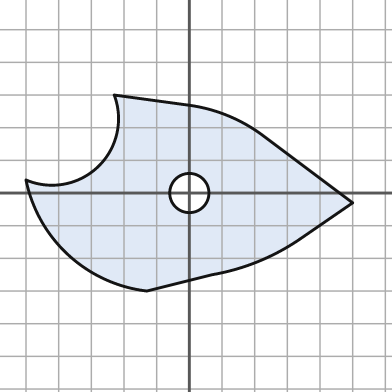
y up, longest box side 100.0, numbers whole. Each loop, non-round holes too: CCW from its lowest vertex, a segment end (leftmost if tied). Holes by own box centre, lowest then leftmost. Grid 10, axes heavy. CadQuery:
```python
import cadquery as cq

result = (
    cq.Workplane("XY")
    .moveTo(-13.0, -30.0)
    .lineTo(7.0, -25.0)
    .threePointArc((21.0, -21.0), (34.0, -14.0))
    .lineTo(50.0, -3.0)
    .lineTo(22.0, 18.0)
    .threePointArc((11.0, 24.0), (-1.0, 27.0))
    .lineTo(-23.0, 30.0)
    .threePointArc((-28.0, 8.0), (-50.0, 4.0))
    .threePointArc((-37.0, -19.0), (-13.0, -30.0))
    .close()
    .moveTo(0.0, 0.0)
    .circle(6.0)
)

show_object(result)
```